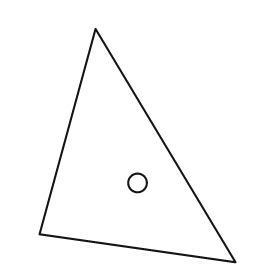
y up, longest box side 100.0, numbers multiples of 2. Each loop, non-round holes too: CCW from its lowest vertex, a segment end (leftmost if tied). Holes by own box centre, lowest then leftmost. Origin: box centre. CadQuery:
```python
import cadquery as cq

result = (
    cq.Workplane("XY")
    .moveTo(42.0, -50.0)
    .lineTo(-18.0, 50.0)
    .lineTo(-42.0, -38.0)
    .close()
    .moveTo(0.0, -16.0)
    .circle(4.0)
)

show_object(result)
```